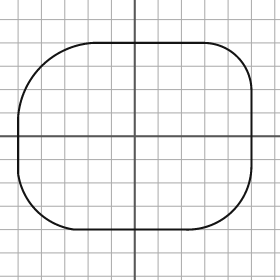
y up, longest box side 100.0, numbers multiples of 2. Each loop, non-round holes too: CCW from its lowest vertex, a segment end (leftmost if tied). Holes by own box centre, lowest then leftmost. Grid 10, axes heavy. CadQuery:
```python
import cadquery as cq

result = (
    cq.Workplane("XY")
    .moveTo(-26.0, -40.0)
    .lineTo(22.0, -40.0)
    .threePointArc((42.0, -32.0), (50.0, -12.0))
    .lineTo(50.0, 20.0)
    .threePointArc((44.0, 34.0), (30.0, 40.0))
    .lineTo(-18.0, 40.0)
    .threePointArc((-40.0, 30.0), (-50.0, 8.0))
    .lineTo(-50.0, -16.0)
    .threePointArc((-42.0, -32.0), (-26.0, -40.0))
    .close()
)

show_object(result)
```